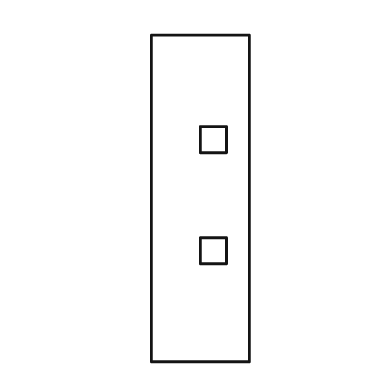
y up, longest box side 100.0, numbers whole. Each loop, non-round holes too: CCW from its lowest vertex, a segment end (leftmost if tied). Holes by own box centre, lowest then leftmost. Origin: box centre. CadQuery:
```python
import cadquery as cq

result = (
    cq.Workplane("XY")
    .moveTo(-15.0, -50.0)
    .lineTo(15.0, -50.0)
    .lineTo(15.0, 50.0)
    .lineTo(-15.0, 50.0)
    .close()
    .moveTo(0.0, -20.0)
    .lineTo(8.0, -20.0)
    .lineTo(8.0, -12.0)
    .lineTo(0.0, -12.0)
    .close()
    .moveTo(0.0, 14.0)
    .lineTo(8.0, 14.0)
    .lineTo(8.0, 22.0)
    .lineTo(0.0, 22.0)
    .close()
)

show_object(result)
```